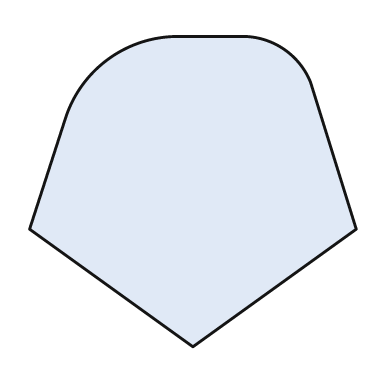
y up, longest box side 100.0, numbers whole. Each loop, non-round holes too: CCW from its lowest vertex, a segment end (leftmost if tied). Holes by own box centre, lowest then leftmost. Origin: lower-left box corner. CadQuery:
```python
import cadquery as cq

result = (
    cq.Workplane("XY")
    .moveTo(50.0, 0.0)
    .lineTo(100.0, 36.0)
    .lineTo(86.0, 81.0)
    .threePointArc((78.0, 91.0), (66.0, 95.0))
    .lineTo(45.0, 95.0)
    .threePointArc((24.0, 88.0), (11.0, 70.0))
    .lineTo(0.0, 36.0)
    .close()
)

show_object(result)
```